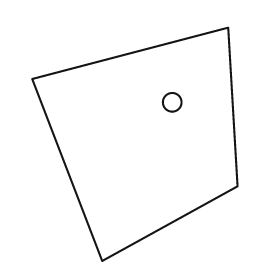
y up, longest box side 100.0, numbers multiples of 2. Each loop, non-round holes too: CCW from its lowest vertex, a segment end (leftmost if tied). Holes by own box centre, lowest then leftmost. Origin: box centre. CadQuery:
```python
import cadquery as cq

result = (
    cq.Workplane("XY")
    .moveTo(-14.0, -50.0)
    .lineTo(44.0, -18.0)
    .lineTo(40.0, 50.0)
    .lineTo(-44.0, 28.0)
    .close()
    .moveTo(16.0, 18.0)
    .circle(4.0)
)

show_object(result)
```